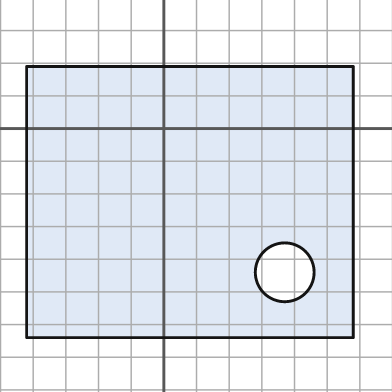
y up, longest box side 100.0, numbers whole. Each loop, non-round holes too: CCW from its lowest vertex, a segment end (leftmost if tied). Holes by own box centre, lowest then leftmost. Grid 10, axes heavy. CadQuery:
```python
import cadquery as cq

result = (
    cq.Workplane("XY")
    .moveTo(-42.0, -64.0)
    .lineTo(58.0, -64.0)
    .lineTo(58.0, 19.0)
    .lineTo(-42.0, 19.0)
    .close()
    .moveTo(37.0, -44.0)
    .circle(9.0)
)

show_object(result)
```